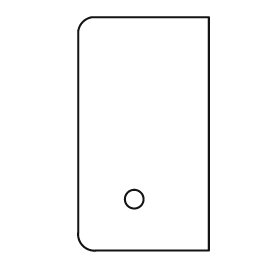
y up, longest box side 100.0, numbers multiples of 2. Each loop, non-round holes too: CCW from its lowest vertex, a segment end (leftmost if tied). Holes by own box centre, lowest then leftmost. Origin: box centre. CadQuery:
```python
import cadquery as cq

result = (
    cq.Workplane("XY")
    .moveTo(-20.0, -50.0)
    .lineTo(28.0, -50.0)
    .lineTo(28.0, 50.0)
    .lineTo(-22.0, 50.0)
    .threePointArc((-26.0, 48.0), (-28.0, 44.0))
    .lineTo(-28.0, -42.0)
    .threePointArc((-26.0, -48.0), (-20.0, -50.0))
    .close()
    .moveTo(-4.0, -28.0)
    .circle(4.0)
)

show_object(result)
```